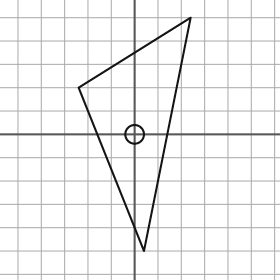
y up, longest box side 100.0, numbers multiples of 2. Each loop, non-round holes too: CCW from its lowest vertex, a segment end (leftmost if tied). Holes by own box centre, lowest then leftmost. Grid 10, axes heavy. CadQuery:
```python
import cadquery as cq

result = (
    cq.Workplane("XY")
    .moveTo(4.0, -50.0)
    .lineTo(24.0, 50.0)
    .lineTo(-24.0, 20.0)
    .close()
    .moveTo(0.0, 0.0)
    .circle(4.0)
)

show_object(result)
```